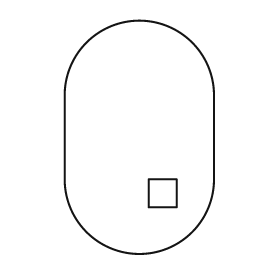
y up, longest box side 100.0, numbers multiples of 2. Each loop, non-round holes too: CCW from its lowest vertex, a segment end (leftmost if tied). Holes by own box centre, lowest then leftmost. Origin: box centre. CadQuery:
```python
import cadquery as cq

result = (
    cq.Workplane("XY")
    .moveTo(-32.0, -18.0)
    .threePointArc((0.0, -50.0), (32.0, -18.0))
    .lineTo(32.0, 18.0)
    .threePointArc((0.0, 50.0), (-32.0, 18.0))
    .close()
    .moveTo(4.0, -30.0)
    .lineTo(16.0, -30.0)
    .lineTo(16.0, -18.0)
    .lineTo(4.0, -18.0)
    .close()
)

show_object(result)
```